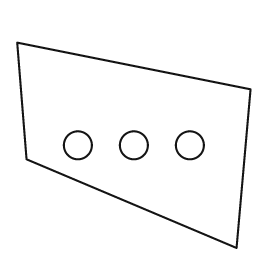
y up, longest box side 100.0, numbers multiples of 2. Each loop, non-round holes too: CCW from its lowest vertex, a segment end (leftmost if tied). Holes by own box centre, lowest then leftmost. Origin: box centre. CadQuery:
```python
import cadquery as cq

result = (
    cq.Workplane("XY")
    .moveTo(44.0, -44.0)
    .lineTo(50.0, 24.0)
    .lineTo(-50.0, 44.0)
    .lineTo(-46.0, -6.0)
    .close()
    .moveTo(-24.0, 0.0)
    .circle(6.0)
    .moveTo(0.0, 0.0)
    .circle(6.0)
    .moveTo(24.0, 0.0)
    .circle(6.0)
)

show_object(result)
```